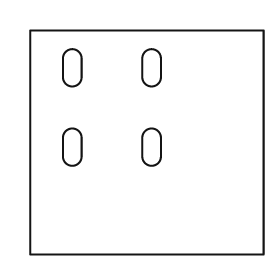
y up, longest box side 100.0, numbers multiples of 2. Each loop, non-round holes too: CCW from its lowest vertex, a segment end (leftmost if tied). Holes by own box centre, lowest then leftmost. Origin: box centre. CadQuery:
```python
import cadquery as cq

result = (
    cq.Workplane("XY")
    .moveTo(-50.0, -48.0)
    .lineTo(50.0, -48.0)
    .lineTo(50.0, 48.0)
    .lineTo(-50.0, 48.0)
    .close()
    .moveTo(-36.0, -6.0)
    .threePointArc((-32.0, -10.0), (-28.0, -6.0))
    .lineTo(-28.0, 2.0)
    .threePointArc((-32.0, 6.0), (-36.0, 2.0))
    .close()
    .moveTo(-2.0, -6.0)
    .threePointArc((2.0, -10.0), (6.0, -6.0))
    .lineTo(6.0, 2.0)
    .threePointArc((2.0, 6.0), (-2.0, 2.0))
    .close()
    .moveTo(-36.0, 28.0)
    .threePointArc((-32.0, 24.0), (-28.0, 28.0))
    .lineTo(-28.0, 36.0)
    .threePointArc((-32.0, 40.0), (-36.0, 36.0))
    .close()
    .moveTo(-2.0, 28.0)
    .threePointArc((2.0, 24.0), (6.0, 28.0))
    .lineTo(6.0, 36.0)
    .threePointArc((2.0, 40.0), (-2.0, 36.0))
    .close()
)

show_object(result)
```